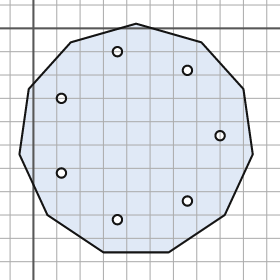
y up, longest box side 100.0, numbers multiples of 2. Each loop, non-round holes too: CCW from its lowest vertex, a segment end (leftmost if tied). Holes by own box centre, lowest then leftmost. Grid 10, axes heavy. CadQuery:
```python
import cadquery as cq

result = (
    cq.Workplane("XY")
    .moveTo(30.0, -96.0)
    .lineTo(58.0, -96.0)
    .lineTo(82.0, -80.0)
    .lineTo(94.0, -54.0)
    .lineTo(90.0, -26.0)
    .lineTo(72.0, -6.0)
    .lineTo(44.0, 2.0)
    .lineTo(16.0, -6.0)
    .lineTo(-2.0, -26.0)
    .lineTo(-6.0, -54.0)
    .lineTo(6.0, -80.0)
    .close()
    .moveTo(36.0, -82.0)
    .circle(2.0)
    .moveTo(66.0, -74.0)
    .circle(2.0)
    .moveTo(12.0, -62.0)
    .circle(2.0)
    .moveTo(80.0, -46.0)
    .circle(2.0)
    .moveTo(12.0, -30.0)
    .circle(2.0)
    .moveTo(66.0, -18.0)
    .circle(2.0)
    .moveTo(36.0, -10.0)
    .circle(2.0)
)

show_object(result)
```